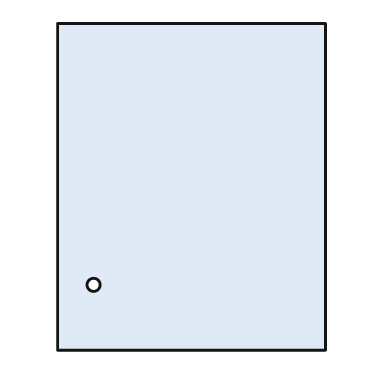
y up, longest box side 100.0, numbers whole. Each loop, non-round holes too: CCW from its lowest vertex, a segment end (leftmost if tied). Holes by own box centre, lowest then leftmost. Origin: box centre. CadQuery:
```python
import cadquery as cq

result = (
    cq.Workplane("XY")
    .moveTo(-41.0, -50.0)
    .lineTo(41.0, -50.0)
    .lineTo(41.0, 50.0)
    .lineTo(-41.0, 50.0)
    .close()
    .moveTo(-30.0, -30.0)
    .circle(2.0)
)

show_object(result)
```